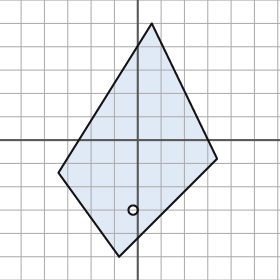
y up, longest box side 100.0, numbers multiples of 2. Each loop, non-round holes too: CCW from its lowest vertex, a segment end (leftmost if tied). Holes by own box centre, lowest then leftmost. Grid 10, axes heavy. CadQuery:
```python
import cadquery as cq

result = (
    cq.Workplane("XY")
    .moveTo(-8.0, -50.0)
    .lineTo(34.0, -8.0)
    .lineTo(6.0, 50.0)
    .lineTo(-34.0, -14.0)
    .close()
    .moveTo(-2.0, -30.0)
    .circle(2.0)
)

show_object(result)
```